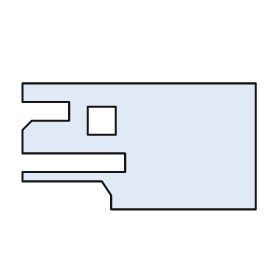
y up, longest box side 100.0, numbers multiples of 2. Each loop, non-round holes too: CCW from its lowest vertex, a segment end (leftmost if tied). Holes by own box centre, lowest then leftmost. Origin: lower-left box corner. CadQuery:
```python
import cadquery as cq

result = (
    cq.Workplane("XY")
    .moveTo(38.0, 0.0)
    .lineTo(100.0, 0.0)
    .lineTo(100.0, 54.0)
    .lineTo(0.0, 54.0)
    .lineTo(0.0, 46.0)
    .lineTo(20.0, 46.0)
    .lineTo(20.0, 38.0)
    .lineTo(4.0, 38.0)
    .lineTo(0.0, 34.0)
    .lineTo(0.0, 24.0)
    .lineTo(44.0, 24.0)
    .lineTo(44.0, 16.0)
    .lineTo(0.0, 16.0)
    .lineTo(0.0, 12.0)
    .lineTo(34.0, 12.0)
    .lineTo(38.0, 6.0)
    .close()
    .moveTo(28.0, 32.0)
    .lineTo(40.0, 32.0)
    .lineTo(40.0, 44.0)
    .lineTo(28.0, 44.0)
    .close()
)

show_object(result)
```